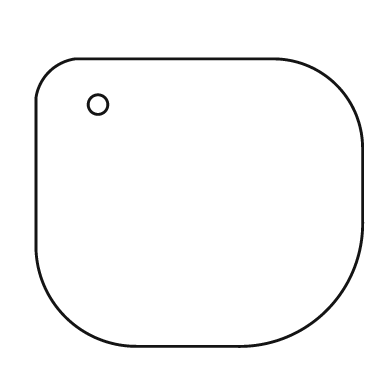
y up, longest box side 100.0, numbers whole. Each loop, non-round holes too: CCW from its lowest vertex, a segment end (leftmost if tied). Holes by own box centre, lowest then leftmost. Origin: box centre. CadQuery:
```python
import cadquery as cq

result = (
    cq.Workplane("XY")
    .moveTo(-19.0, -44.0)
    .lineTo(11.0, -44.0)
    .threePointArc((39.0, -33.0), (50.0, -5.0))
    .lineTo(50.0, 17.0)
    .threePointArc((42.0, 36.0), (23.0, 44.0))
    .lineTo(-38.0, 44.0)
    .threePointArc((-46.0, 40.0), (-50.0, 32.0))
    .lineTo(-50.0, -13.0)
    .threePointArc((-41.0, -35.0), (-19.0, -44.0))
    .close()
    .moveTo(-31.0, 30.0)
    .circle(3.0)
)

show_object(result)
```